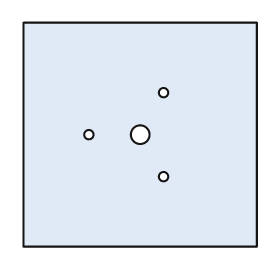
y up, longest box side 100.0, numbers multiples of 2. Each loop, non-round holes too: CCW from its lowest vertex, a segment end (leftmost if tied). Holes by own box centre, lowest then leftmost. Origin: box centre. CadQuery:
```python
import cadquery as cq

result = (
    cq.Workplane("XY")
    .moveTo(-50.0, -48.0)
    .lineTo(50.0, -48.0)
    .lineTo(50.0, 48.0)
    .lineTo(-50.0, 48.0)
    .close()
    .moveTo(10.0, -18.0)
    .circle(2.0)
    .moveTo(-22.0, 0.0)
    .circle(2.0)
    .moveTo(0.0, 0.0)
    .circle(4.0)
    .moveTo(10.0, 18.0)
    .circle(2.0)
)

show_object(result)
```